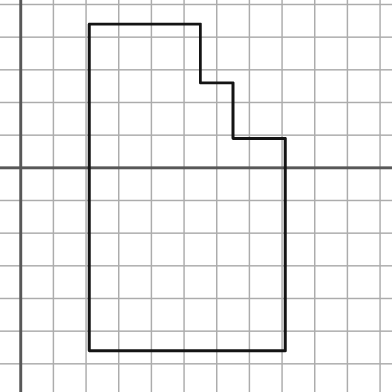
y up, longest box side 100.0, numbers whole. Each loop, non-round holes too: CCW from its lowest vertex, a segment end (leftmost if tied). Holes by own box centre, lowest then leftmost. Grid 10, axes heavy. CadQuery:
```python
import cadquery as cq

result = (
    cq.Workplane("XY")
    .moveTo(21.0, -56.0)
    .lineTo(81.0, -56.0)
    .lineTo(81.0, 9.0)
    .lineTo(65.0, 9.0)
    .lineTo(65.0, 26.0)
    .lineTo(55.0, 26.0)
    .lineTo(55.0, 44.0)
    .lineTo(21.0, 44.0)
    .close()
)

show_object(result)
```